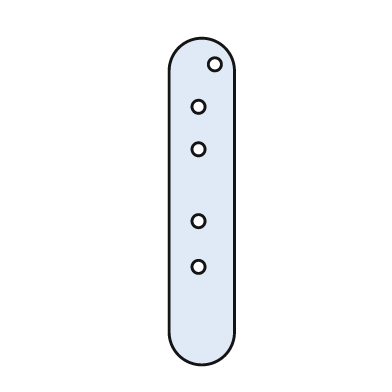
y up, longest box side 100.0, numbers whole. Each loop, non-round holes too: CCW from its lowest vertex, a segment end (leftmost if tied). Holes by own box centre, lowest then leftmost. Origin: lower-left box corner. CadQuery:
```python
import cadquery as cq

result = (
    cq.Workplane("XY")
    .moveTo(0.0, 10.0)
    .threePointArc((10.0, 0.0), (20.0, 10.0))
    .lineTo(20.0, 90.0)
    .threePointArc((10.0, 100.0), (0.0, 90.0))
    .close()
    .moveTo(9.0, 30.0)
    .circle(2.0)
    .moveTo(9.0, 44.0)
    .circle(2.0)
    .moveTo(9.0, 66.0)
    .circle(2.0)
    .moveTo(9.0, 79.0)
    .circle(2.0)
    .moveTo(14.0, 92.0)
    .circle(2.0)
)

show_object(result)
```